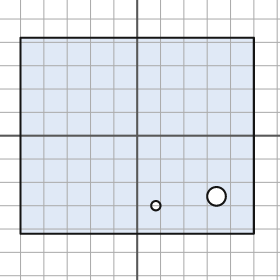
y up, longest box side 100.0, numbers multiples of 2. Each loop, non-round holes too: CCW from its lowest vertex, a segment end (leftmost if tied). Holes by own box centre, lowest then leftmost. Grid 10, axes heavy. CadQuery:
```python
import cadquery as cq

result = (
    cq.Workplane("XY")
    .moveTo(-50.0, -42.0)
    .lineTo(50.0, -42.0)
    .lineTo(50.0, 42.0)
    .lineTo(-50.0, 42.0)
    .close()
    .moveTo(8.0, -30.0)
    .circle(2.0)
    .moveTo(34.0, -26.0)
    .circle(4.0)
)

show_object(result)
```